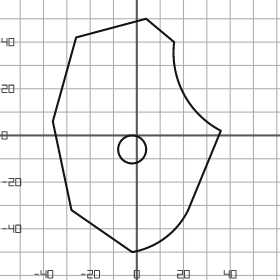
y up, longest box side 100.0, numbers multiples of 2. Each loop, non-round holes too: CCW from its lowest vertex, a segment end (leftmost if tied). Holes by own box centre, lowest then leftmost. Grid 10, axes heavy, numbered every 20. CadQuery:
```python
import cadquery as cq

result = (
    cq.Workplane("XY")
    .moveTo(-2.0, -50.0)
    .threePointArc((12.0, -44.0), (22.0, -32.0))
    .lineTo(36.0, 2.0)
    .threePointArc((20.0, 18.0), (16.0, 40.0))
    .lineTo(4.0, 50.0)
    .lineTo(-26.0, 42.0)
    .lineTo(-36.0, 6.0)
    .lineTo(-28.0, -32.0)
    .close()
    .moveTo(-2.0, -6.0)
    .circle(6.0)
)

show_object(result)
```